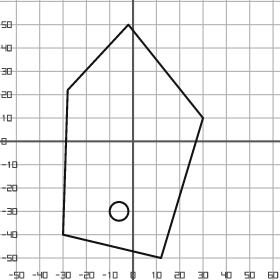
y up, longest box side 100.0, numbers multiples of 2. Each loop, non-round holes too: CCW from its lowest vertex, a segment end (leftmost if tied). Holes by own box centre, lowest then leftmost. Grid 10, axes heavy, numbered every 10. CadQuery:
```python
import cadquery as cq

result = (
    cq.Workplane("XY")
    .moveTo(12.0, -50.0)
    .lineTo(30.0, 10.0)
    .lineTo(-2.0, 50.0)
    .lineTo(-28.0, 22.0)
    .lineTo(-30.0, -40.0)
    .close()
    .moveTo(-6.0, -30.0)
    .circle(4.0)
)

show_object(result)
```